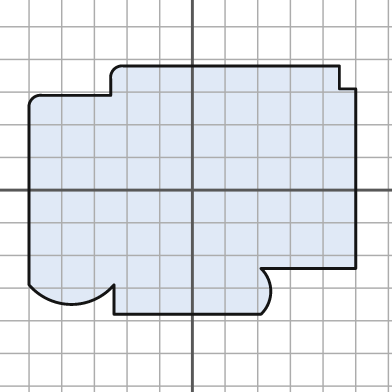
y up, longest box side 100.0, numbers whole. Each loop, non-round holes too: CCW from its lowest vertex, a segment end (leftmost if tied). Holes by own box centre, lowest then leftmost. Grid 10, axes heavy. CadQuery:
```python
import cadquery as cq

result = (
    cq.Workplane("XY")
    .moveTo(-24.0, -38.0)
    .lineTo(21.0, -38.0)
    .threePointArc((24.0, -31.0), (21.0, -24.0))
    .lineTo(50.0, -24.0)
    .lineTo(50.0, 31.0)
    .lineTo(45.0, 31.0)
    .lineTo(45.0, 38.0)
    .lineTo(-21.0, 38.0)
    .threePointArc((-24.0, 37.0), (-25.0, 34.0))
    .lineTo(-25.0, 29.0)
    .lineTo(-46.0, 29.0)
    .threePointArc((-49.0, 28.0), (-50.0, 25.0))
    .lineTo(-50.0, -29.0)
    .threePointArc((-37.0, -35.0), (-24.0, -29.0))
    .close()
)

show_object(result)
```